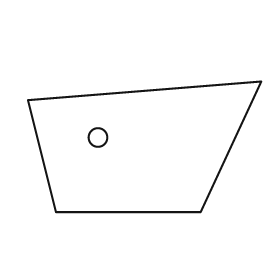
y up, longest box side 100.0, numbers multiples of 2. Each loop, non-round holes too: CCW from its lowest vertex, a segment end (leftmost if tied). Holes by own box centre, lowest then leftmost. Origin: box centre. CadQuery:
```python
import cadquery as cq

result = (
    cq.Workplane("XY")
    .moveTo(-38.0, -28.0)
    .lineTo(24.0, -28.0)
    .lineTo(50.0, 28.0)
    .lineTo(-50.0, 20.0)
    .close()
    .moveTo(-20.0, 4.0)
    .circle(4.0)
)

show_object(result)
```